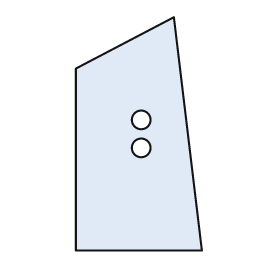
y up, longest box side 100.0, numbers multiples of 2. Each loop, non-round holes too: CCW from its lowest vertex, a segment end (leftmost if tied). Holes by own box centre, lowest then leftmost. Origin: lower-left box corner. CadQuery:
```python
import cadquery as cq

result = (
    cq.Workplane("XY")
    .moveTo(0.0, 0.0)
    .lineTo(54.0, 0.0)
    .lineTo(42.0, 100.0)
    .lineTo(0.0, 78.0)
    .close()
    .moveTo(28.0, 44.0)
    .circle(4.0)
    .moveTo(28.0, 56.0)
    .circle(4.0)
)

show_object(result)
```